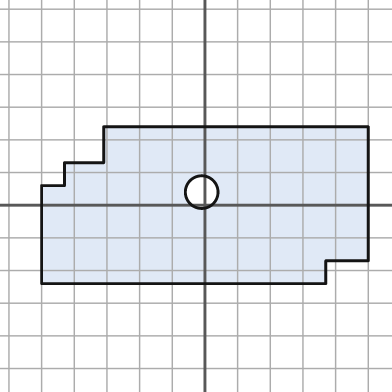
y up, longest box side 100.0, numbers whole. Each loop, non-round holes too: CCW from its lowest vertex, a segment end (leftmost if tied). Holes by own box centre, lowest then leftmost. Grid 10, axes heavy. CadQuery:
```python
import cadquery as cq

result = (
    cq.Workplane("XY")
    .moveTo(-50.0, -24.0)
    .lineTo(37.0, -24.0)
    .lineTo(37.0, -17.0)
    .lineTo(50.0, -17.0)
    .lineTo(50.0, 24.0)
    .lineTo(-31.0, 24.0)
    .lineTo(-31.0, 13.0)
    .lineTo(-43.0, 13.0)
    .lineTo(-43.0, 6.0)
    .lineTo(-50.0, 6.0)
    .close()
    .moveTo(-1.0, 4.0)
    .circle(5.0)
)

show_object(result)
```